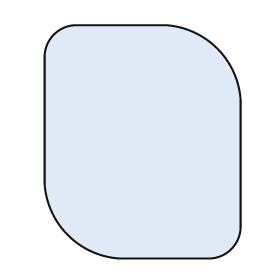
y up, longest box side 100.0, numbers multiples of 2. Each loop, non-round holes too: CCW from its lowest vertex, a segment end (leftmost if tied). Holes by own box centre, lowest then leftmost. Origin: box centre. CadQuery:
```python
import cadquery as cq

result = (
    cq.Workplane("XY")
    .moveTo(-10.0, -50.0)
    .lineTo(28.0, -50.0)
    .threePointArc((38.0, -46.0), (42.0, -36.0))
    .lineTo(42.0, 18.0)
    .threePointArc((32.0, 40.0), (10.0, 50.0))
    .lineTo(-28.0, 50.0)
    .threePointArc((-38.0, 46.0), (-42.0, 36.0))
    .lineTo(-42.0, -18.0)
    .threePointArc((-32.0, -40.0), (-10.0, -50.0))
    .close()
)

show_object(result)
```